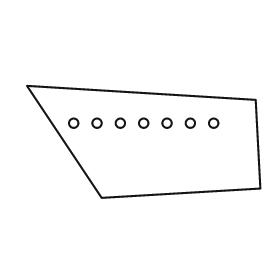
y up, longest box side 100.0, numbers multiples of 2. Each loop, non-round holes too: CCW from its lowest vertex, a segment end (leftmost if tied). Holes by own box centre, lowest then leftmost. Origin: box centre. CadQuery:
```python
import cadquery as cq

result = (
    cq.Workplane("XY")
    .moveTo(-18.0, -24.0)
    .lineTo(50.0, -20.0)
    .lineTo(48.0, 18.0)
    .lineTo(-50.0, 24.0)
    .close()
    .moveTo(-30.0, 8.0)
    .circle(2.0)
    .moveTo(-20.0, 8.0)
    .circle(2.0)
    .moveTo(-10.0, 8.0)
    .circle(2.0)
    .moveTo(0.0, 8.0)
    .circle(2.0)
    .moveTo(10.0, 8.0)
    .circle(2.0)
    .moveTo(20.0, 8.0)
    .circle(2.0)
    .moveTo(30.0, 8.0)
    .circle(2.0)
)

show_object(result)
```